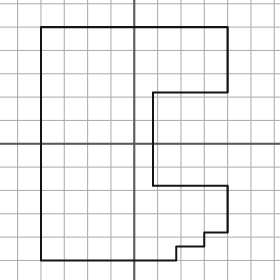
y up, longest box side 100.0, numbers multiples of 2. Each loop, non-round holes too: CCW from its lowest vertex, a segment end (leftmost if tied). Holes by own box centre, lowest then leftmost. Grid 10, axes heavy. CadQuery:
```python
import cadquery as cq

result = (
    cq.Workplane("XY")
    .moveTo(-40.0, -50.0)
    .lineTo(18.0, -50.0)
    .lineTo(18.0, -44.0)
    .lineTo(30.0, -44.0)
    .lineTo(30.0, -38.0)
    .lineTo(40.0, -38.0)
    .lineTo(40.0, -18.0)
    .lineTo(8.0, -18.0)
    .lineTo(8.0, 22.0)
    .lineTo(40.0, 22.0)
    .lineTo(40.0, 50.0)
    .lineTo(-40.0, 50.0)
    .close()
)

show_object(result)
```